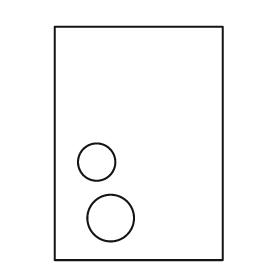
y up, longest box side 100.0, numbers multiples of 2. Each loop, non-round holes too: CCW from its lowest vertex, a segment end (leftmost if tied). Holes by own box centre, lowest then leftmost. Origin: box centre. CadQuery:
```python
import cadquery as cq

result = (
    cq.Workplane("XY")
    .moveTo(-36.0, -50.0)
    .lineTo(36.0, -50.0)
    .lineTo(36.0, 50.0)
    .lineTo(-36.0, 50.0)
    .close()
    .moveTo(-12.0, -32.0)
    .circle(10.0)
    .moveTo(-18.0, -8.0)
    .circle(8.0)
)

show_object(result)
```